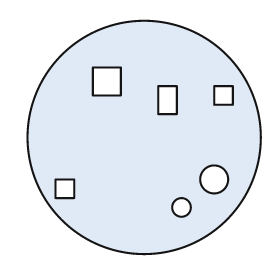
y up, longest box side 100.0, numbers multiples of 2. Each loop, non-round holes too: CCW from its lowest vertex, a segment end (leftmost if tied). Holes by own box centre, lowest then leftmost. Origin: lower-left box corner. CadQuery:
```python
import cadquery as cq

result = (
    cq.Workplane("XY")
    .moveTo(50.0, 50.0)
    .circle(50.0)
    .moveTo(66.0, 20.0)
    .circle(4.0)
    .moveTo(12.0, 24.0)
    .lineTo(20.0, 24.0)
    .lineTo(20.0, 32.0)
    .lineTo(12.0, 32.0)
    .close()
    .moveTo(80.0, 32.0)
    .circle(6.0)
    .moveTo(56.0, 60.0)
    .lineTo(64.0, 60.0)
    .lineTo(64.0, 72.0)
    .lineTo(56.0, 72.0)
    .close()
    .moveTo(80.0, 64.0)
    .lineTo(88.0, 64.0)
    .lineTo(88.0, 72.0)
    .lineTo(80.0, 72.0)
    .close()
    .moveTo(28.0, 68.0)
    .lineTo(40.0, 68.0)
    .lineTo(40.0, 80.0)
    .lineTo(28.0, 80.0)
    .close()
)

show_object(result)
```